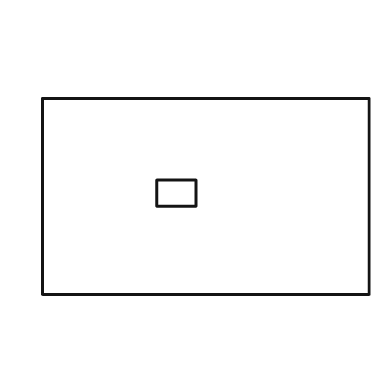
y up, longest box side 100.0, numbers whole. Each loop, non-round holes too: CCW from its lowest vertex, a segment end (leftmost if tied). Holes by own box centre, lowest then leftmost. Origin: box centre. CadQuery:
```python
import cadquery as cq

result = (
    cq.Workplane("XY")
    .moveTo(-50.0, -30.0)
    .lineTo(50.0, -30.0)
    .lineTo(50.0, 30.0)
    .lineTo(-50.0, 30.0)
    .close()
    .moveTo(-15.0, -3.0)
    .lineTo(-3.0, -3.0)
    .lineTo(-3.0, 5.0)
    .lineTo(-15.0, 5.0)
    .close()
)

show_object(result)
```